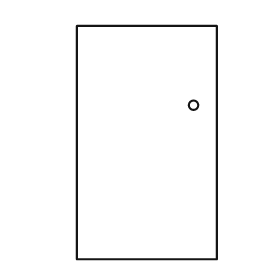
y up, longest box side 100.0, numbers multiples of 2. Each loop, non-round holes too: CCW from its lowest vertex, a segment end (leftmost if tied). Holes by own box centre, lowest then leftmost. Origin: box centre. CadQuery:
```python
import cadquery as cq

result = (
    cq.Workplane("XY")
    .moveTo(-30.0, -50.0)
    .lineTo(30.0, -50.0)
    .lineTo(30.0, 50.0)
    .lineTo(-30.0, 50.0)
    .close()
    .moveTo(20.0, 16.0)
    .circle(2.0)
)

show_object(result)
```